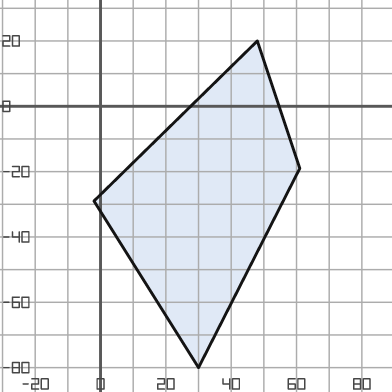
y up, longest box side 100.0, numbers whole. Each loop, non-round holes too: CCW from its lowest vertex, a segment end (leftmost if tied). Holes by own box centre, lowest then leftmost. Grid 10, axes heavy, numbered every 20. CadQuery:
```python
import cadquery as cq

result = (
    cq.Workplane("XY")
    .moveTo(30.0, -80.0)
    .lineTo(61.0, -19.0)
    .lineTo(48.0, 20.0)
    .lineTo(-2.0, -29.0)
    .close()
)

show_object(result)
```